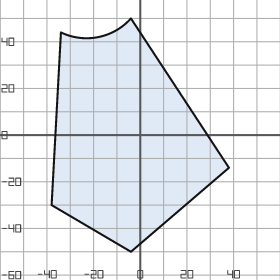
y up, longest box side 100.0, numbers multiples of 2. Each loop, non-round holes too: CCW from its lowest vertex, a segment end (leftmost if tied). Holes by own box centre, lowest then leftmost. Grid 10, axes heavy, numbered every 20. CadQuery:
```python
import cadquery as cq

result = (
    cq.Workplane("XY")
    .moveTo(-4.0, -50.0)
    .lineTo(38.0, -14.0)
    .lineTo(-4.0, 50.0)
    .threePointArc((-18.0, 42.0), (-34.0, 44.0))
    .lineTo(-38.0, -30.0)
    .close()
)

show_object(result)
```